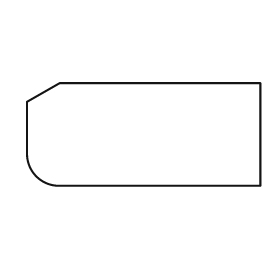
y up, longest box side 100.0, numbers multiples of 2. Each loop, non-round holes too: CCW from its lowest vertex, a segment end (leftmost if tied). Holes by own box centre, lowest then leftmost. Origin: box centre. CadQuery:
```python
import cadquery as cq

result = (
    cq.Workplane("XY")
    .moveTo(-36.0, -22.0)
    .lineTo(50.0, -22.0)
    .lineTo(50.0, 22.0)
    .lineTo(-36.0, 22.0)
    .lineTo(-50.0, 14.0)
    .lineTo(-50.0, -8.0)
    .threePointArc((-46.0, -18.0), (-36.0, -22.0))
    .close()
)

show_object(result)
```